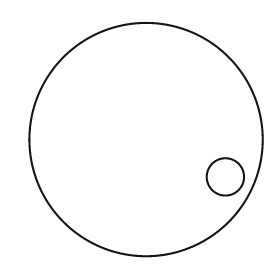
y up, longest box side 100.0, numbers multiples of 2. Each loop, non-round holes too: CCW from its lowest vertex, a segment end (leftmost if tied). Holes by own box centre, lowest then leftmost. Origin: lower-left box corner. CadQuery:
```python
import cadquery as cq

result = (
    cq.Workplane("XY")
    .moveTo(50.0, 50.0)
    .circle(50.0)
    .moveTo(84.0, 34.0)
    .circle(8.0)
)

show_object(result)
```